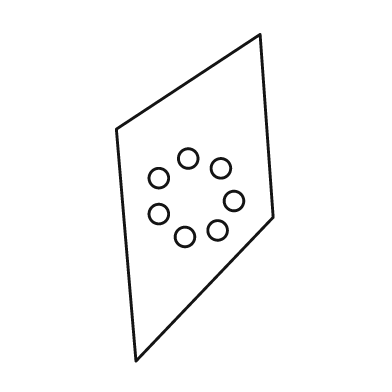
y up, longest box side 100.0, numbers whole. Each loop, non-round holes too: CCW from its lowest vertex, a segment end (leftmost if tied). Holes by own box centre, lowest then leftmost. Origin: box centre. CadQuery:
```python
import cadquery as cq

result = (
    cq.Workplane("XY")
    .moveTo(-18.0, -50.0)
    .lineTo(24.0, -6.0)
    .lineTo(20.0, 50.0)
    .lineTo(-24.0, 21.0)
    .close()
    .moveTo(-3.0, -12.0)
    .circle(3.0)
    .moveTo(7.0, -10.0)
    .circle(3.0)
    .moveTo(-11.0, -5.0)
    .circle(3.0)
    .moveTo(12.0, -1.0)
    .circle(3.0)
    .moveTo(-11.0, 6.0)
    .circle(3.0)
    .moveTo(8.0, 9.0)
    .circle(3.0)
    .moveTo(-2.0, 12.0)
    .circle(3.0)
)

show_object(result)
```